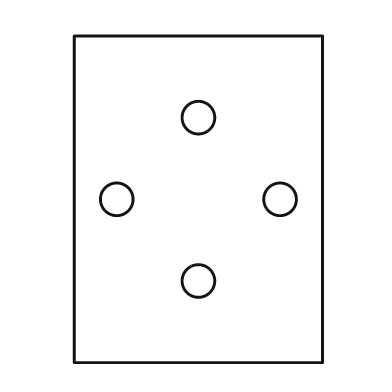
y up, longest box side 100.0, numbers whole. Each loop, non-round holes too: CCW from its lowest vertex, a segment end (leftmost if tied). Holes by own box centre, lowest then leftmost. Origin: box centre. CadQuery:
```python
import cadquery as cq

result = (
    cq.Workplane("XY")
    .moveTo(-38.0, -50.0)
    .lineTo(38.0, -50.0)
    .lineTo(38.0, 50.0)
    .lineTo(-38.0, 50.0)
    .close()
    .moveTo(0.0, -25.0)
    .circle(5.0)
    .moveTo(-25.0, 0.0)
    .circle(5.0)
    .moveTo(25.0, 0.0)
    .circle(5.0)
    .moveTo(0.0, 25.0)
    .circle(5.0)
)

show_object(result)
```